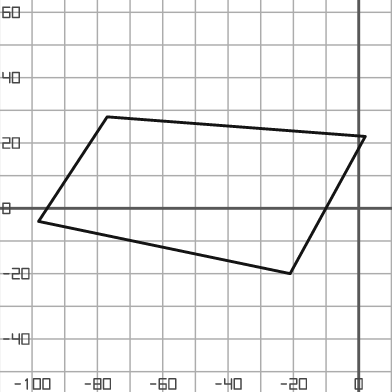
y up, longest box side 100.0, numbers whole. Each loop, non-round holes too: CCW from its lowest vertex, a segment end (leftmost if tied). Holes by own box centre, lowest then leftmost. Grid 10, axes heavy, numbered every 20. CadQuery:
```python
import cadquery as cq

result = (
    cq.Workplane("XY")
    .moveTo(-21.0, -20.0)
    .lineTo(2.0, 22.0)
    .lineTo(-77.0, 28.0)
    .lineTo(-98.0, -4.0)
    .close()
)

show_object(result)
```